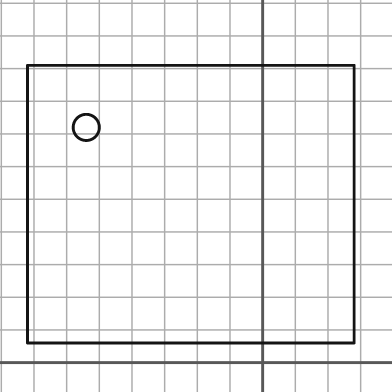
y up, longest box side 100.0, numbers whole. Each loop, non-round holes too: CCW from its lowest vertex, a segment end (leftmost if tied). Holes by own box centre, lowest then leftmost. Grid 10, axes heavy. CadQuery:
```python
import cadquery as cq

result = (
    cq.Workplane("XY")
    .moveTo(-72.0, 6.0)
    .lineTo(28.0, 6.0)
    .lineTo(28.0, 91.0)
    .lineTo(-72.0, 91.0)
    .close()
    .moveTo(-54.0, 72.0)
    .circle(4.0)
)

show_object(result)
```